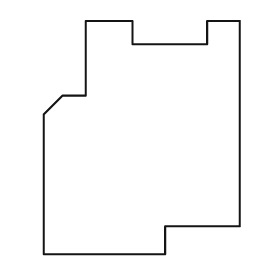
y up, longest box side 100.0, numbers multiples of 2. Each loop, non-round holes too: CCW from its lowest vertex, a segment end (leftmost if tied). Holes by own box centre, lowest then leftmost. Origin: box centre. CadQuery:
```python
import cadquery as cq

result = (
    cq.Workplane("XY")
    .moveTo(-42.0, -50.0)
    .lineTo(10.0, -50.0)
    .lineTo(10.0, -38.0)
    .lineTo(42.0, -38.0)
    .lineTo(42.0, 50.0)
    .lineTo(28.0, 50.0)
    .lineTo(28.0, 40.0)
    .lineTo(-4.0, 40.0)
    .lineTo(-4.0, 50.0)
    .lineTo(-24.0, 50.0)
    .lineTo(-24.0, 18.0)
    .lineTo(-34.0, 18.0)
    .lineTo(-42.0, 10.0)
    .close()
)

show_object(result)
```